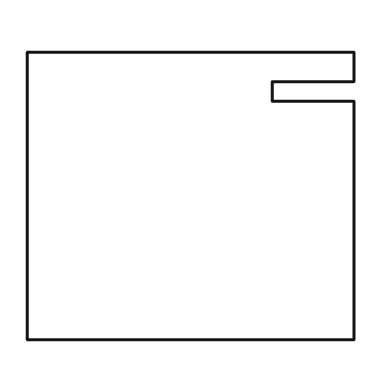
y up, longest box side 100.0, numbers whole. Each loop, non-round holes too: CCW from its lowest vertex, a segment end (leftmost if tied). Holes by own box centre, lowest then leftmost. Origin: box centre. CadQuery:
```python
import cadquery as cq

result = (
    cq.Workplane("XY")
    .moveTo(-50.0, -44.0)
    .lineTo(50.0, -44.0)
    .lineTo(50.0, 29.0)
    .lineTo(25.0, 29.0)
    .lineTo(25.0, 35.0)
    .lineTo(50.0, 35.0)
    .lineTo(50.0, 44.0)
    .lineTo(-50.0, 44.0)
    .close()
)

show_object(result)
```